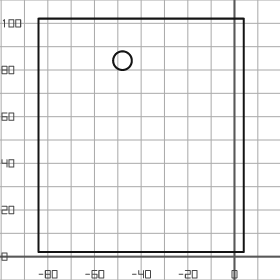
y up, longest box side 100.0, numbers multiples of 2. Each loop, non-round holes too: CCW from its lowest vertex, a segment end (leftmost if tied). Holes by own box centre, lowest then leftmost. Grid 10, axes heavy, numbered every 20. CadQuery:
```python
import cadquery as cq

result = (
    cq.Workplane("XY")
    .moveTo(-84.0, 2.0)
    .lineTo(4.0, 2.0)
    .lineTo(4.0, 102.0)
    .lineTo(-84.0, 102.0)
    .close()
    .moveTo(-48.0, 84.0)
    .circle(4.0)
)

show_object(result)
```